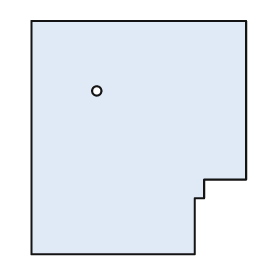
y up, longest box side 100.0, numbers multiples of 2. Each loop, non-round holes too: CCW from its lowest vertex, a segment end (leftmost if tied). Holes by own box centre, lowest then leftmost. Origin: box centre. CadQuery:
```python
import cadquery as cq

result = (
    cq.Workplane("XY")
    .moveTo(-46.0, -50.0)
    .lineTo(24.0, -50.0)
    .lineTo(24.0, -26.0)
    .lineTo(28.0, -26.0)
    .lineTo(28.0, -18.0)
    .lineTo(46.0, -18.0)
    .lineTo(46.0, 50.0)
    .lineTo(-46.0, 50.0)
    .close()
    .moveTo(-18.0, 20.0)
    .circle(2.0)
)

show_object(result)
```